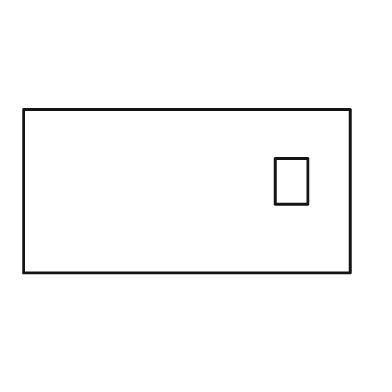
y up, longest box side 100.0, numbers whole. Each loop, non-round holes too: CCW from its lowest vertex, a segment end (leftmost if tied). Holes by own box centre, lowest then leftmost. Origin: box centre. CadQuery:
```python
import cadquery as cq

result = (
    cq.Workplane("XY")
    .moveTo(-50.0, -25.0)
    .lineTo(50.0, -25.0)
    .lineTo(50.0, 25.0)
    .lineTo(-50.0, 25.0)
    .close()
    .moveTo(27.0, -4.0)
    .lineTo(37.0, -4.0)
    .lineTo(37.0, 10.0)
    .lineTo(27.0, 10.0)
    .close()
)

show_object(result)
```